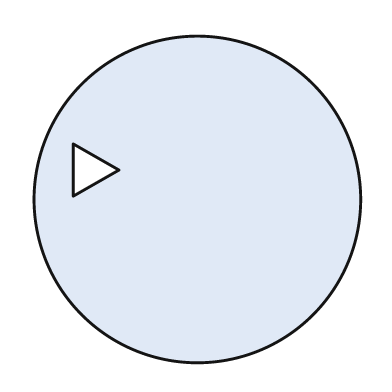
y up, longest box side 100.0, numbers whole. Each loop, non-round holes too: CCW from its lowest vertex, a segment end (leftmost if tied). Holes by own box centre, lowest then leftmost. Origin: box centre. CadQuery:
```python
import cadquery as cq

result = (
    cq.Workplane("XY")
    .moveTo(0.0, 0.0)
    .circle(50.0)
    .moveTo(-38.0, 1.0)
    .lineTo(-24.0, 9.0)
    .lineTo(-38.0, 17.0)
    .close()
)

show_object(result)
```